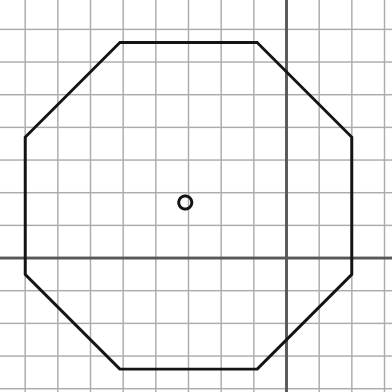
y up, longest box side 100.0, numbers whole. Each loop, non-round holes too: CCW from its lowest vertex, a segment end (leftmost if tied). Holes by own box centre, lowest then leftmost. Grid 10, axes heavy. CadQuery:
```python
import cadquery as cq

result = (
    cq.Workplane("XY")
    .moveTo(-51.0, -34.0)
    .lineTo(-9.0, -34.0)
    .lineTo(20.0, -5.0)
    .lineTo(20.0, 37.0)
    .lineTo(-9.0, 66.0)
    .lineTo(-51.0, 66.0)
    .lineTo(-80.0, 37.0)
    .lineTo(-80.0, -5.0)
    .close()
    .moveTo(-31.0, 17.0)
    .circle(2.0)
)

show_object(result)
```